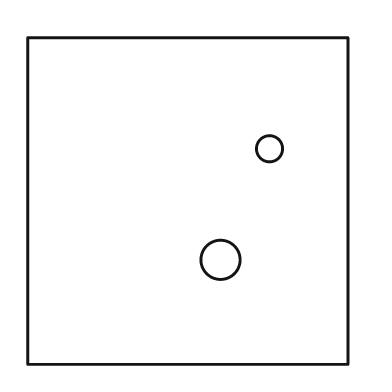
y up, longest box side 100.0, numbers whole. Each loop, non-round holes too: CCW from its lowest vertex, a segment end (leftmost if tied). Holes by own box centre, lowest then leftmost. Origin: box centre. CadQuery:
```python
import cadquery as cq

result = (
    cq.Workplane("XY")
    .moveTo(-49.0, -50.0)
    .lineTo(49.0, -50.0)
    .lineTo(49.0, 50.0)
    .lineTo(-49.0, 50.0)
    .close()
    .moveTo(10.0, -18.0)
    .circle(6.0)
    .moveTo(25.0, 16.0)
    .circle(4.0)
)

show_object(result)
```